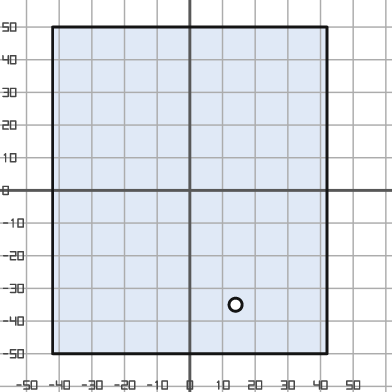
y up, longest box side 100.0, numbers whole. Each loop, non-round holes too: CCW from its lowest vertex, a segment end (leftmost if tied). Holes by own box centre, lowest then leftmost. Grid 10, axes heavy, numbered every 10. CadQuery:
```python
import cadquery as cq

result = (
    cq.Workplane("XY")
    .moveTo(-42.0, -50.0)
    .lineTo(42.0, -50.0)
    .lineTo(42.0, 50.0)
    .lineTo(-42.0, 50.0)
    .close()
    .moveTo(14.0, -35.0)
    .circle(2.0)
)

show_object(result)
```